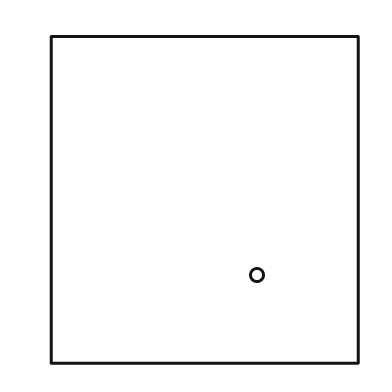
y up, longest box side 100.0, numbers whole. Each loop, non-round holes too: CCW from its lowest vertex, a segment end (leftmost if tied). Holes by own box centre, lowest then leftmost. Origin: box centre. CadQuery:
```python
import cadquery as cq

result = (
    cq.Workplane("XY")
    .moveTo(-47.0, -50.0)
    .lineTo(47.0, -50.0)
    .lineTo(47.0, 50.0)
    .lineTo(-47.0, 50.0)
    .close()
    .moveTo(16.0, -23.0)
    .circle(2.0)
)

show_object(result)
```